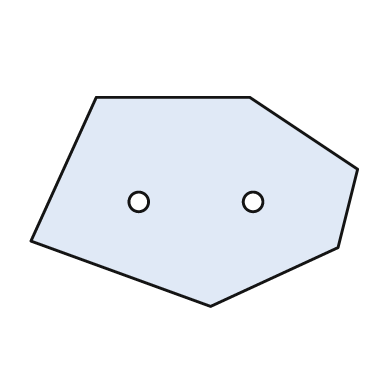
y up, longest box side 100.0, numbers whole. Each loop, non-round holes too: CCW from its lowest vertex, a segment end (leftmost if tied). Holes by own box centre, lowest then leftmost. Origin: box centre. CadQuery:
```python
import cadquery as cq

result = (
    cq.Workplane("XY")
    .moveTo(5.0, -32.0)
    .lineTo(44.0, -14.0)
    .lineTo(50.0, 10.0)
    .lineTo(17.0, 32.0)
    .lineTo(-30.0, 32.0)
    .lineTo(-50.0, -12.0)
    .close()
    .moveTo(-17.0, 0.0)
    .circle(3.0)
    .moveTo(18.0, 0.0)
    .circle(3.0)
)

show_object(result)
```